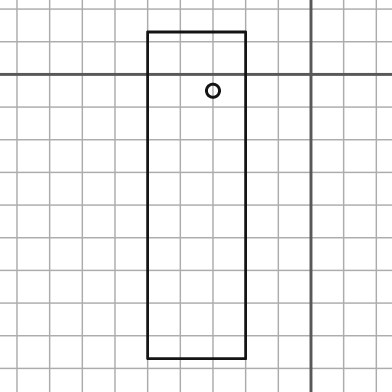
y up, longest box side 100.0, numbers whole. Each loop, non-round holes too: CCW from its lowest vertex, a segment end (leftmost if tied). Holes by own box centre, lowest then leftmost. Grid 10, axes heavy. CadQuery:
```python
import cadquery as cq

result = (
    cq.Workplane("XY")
    .moveTo(-50.0, -87.0)
    .lineTo(-20.0, -87.0)
    .lineTo(-20.0, 13.0)
    .lineTo(-50.0, 13.0)
    .close()
    .moveTo(-30.0, -5.0)
    .circle(2.0)
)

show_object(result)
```